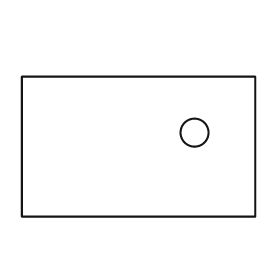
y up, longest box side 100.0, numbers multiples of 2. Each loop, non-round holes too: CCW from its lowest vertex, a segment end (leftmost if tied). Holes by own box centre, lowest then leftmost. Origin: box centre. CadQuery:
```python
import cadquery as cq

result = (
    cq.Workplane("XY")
    .moveTo(-50.0, -30.0)
    .lineTo(50.0, -30.0)
    .lineTo(50.0, 30.0)
    .lineTo(-50.0, 30.0)
    .close()
    .moveTo(24.0, 6.0)
    .circle(6.0)
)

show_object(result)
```